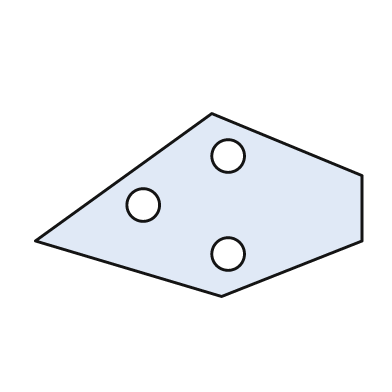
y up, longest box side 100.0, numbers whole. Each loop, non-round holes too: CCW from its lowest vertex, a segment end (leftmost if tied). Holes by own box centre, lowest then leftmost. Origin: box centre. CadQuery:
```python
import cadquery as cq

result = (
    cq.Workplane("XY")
    .moveTo(7.0, -28.0)
    .lineTo(50.0, -11.0)
    .lineTo(50.0, 9.0)
    .lineTo(4.0, 28.0)
    .lineTo(-50.0, -11.0)
    .close()
    .moveTo(9.0, -15.0)
    .circle(5.0)
    .moveTo(-17.0, 0.0)
    .circle(5.0)
    .moveTo(9.0, 15.0)
    .circle(5.0)
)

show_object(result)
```